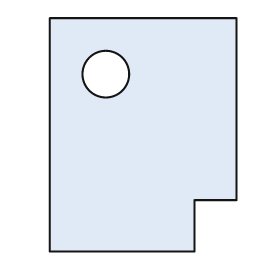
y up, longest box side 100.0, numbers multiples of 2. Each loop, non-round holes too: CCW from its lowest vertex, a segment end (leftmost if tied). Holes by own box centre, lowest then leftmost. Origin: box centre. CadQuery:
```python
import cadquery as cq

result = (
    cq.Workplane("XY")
    .moveTo(-40.0, -50.0)
    .lineTo(22.0, -50.0)
    .lineTo(22.0, -28.0)
    .lineTo(40.0, -28.0)
    .lineTo(40.0, 50.0)
    .lineTo(-40.0, 50.0)
    .close()
    .moveTo(-16.0, 26.0)
    .circle(10.0)
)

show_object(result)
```